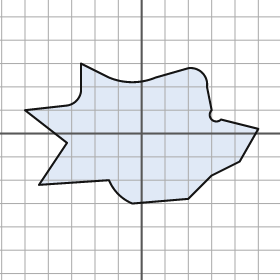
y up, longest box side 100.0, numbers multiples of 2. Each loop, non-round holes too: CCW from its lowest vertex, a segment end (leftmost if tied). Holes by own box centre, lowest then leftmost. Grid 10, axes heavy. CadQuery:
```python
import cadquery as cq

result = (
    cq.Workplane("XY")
    .moveTo(-4.0, -30.0)
    .lineTo(20.0, -28.0)
    .lineTo(30.0, -18.0)
    .lineTo(42.0, -12.0)
    .lineTo(50.0, 2.0)
    .lineTo(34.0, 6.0)
    .threePointArc((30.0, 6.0), (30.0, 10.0))
    .lineTo(28.0, 20.0)
    .threePointArc((26.0, 26.0), (20.0, 28.0))
    .lineTo(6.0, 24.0)
    .threePointArc((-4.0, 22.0), (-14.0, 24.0))
    .lineTo(-26.0, 30.0)
    .lineTo(-26.0, 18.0)
    .threePointArc((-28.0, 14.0), (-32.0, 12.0))
    .lineTo(-50.0, 10.0)
    .lineTo(-32.0, -4.0)
    .lineTo(-44.0, -22.0)
    .lineTo(-14.0, -20.0)
    .threePointArc((-10.0, -26.0), (-4.0, -30.0))
    .close()
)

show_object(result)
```